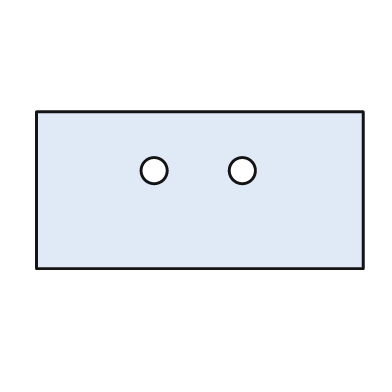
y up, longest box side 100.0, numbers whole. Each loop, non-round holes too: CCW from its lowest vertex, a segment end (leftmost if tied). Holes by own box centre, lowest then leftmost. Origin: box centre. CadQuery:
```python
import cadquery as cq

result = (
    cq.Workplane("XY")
    .moveTo(-50.0, -24.0)
    .lineTo(50.0, -24.0)
    .lineTo(50.0, 24.0)
    .lineTo(-50.0, 24.0)
    .close()
    .moveTo(-14.0, 6.0)
    .circle(4.0)
    .moveTo(13.0, 6.0)
    .circle(4.0)
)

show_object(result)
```